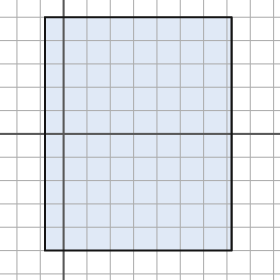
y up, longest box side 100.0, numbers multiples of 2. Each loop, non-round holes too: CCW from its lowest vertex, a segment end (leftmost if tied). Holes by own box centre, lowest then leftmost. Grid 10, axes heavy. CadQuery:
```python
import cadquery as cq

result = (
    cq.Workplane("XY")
    .moveTo(-8.0, -50.0)
    .lineTo(72.0, -50.0)
    .lineTo(72.0, 50.0)
    .lineTo(-8.0, 50.0)
    .close()
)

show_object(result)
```